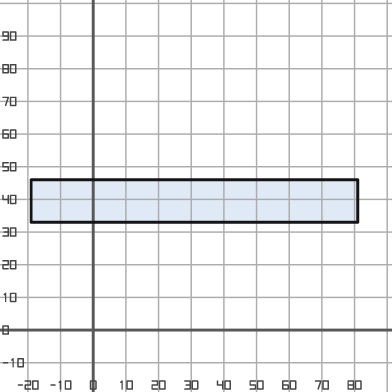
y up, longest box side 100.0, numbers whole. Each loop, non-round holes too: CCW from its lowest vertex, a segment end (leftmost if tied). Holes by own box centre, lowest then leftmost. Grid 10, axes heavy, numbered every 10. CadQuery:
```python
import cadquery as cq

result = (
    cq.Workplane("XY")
    .moveTo(-19.0, 33.0)
    .lineTo(81.0, 33.0)
    .lineTo(81.0, 46.0)
    .lineTo(-19.0, 46.0)
    .close()
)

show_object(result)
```